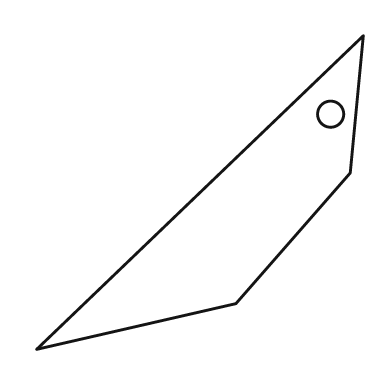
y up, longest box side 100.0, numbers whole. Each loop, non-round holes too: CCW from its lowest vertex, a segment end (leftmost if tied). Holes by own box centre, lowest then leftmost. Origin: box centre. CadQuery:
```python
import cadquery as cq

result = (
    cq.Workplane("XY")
    .moveTo(-50.0, -48.0)
    .lineTo(11.0, -34.0)
    .lineTo(46.0, 6.0)
    .lineTo(50.0, 48.0)
    .close()
    .moveTo(40.0, 24.0)
    .circle(4.0)
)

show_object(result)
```